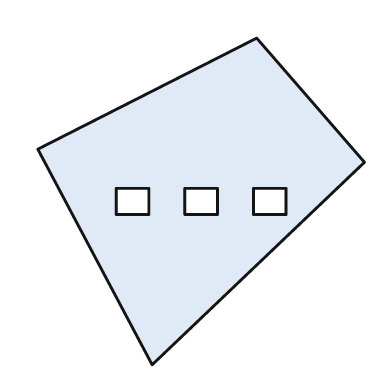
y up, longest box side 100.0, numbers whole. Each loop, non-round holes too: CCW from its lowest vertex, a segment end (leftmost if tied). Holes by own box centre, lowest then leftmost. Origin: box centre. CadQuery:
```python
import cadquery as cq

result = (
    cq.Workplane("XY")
    .moveTo(-15.0, -50.0)
    .lineTo(50.0, 12.0)
    .lineTo(17.0, 50.0)
    .lineTo(-50.0, 16.0)
    .close()
    .moveTo(-26.0, -4.0)
    .lineTo(-16.0, -4.0)
    .lineTo(-16.0, 4.0)
    .lineTo(-26.0, 4.0)
    .close()
    .moveTo(-5.0, -4.0)
    .lineTo(5.0, -4.0)
    .lineTo(5.0, 4.0)
    .lineTo(-5.0, 4.0)
    .close()
    .moveTo(16.0, -4.0)
    .lineTo(26.0, -4.0)
    .lineTo(26.0, 4.0)
    .lineTo(16.0, 4.0)
    .close()
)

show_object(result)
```